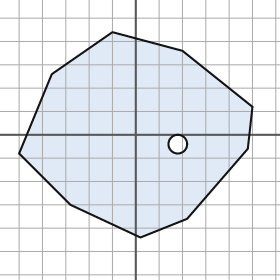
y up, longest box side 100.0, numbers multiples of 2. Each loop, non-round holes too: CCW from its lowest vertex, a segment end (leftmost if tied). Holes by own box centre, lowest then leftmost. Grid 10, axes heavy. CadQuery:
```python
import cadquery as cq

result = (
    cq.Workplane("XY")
    .moveTo(2.0, -44.0)
    .lineTo(22.0, -36.0)
    .lineTo(48.0, -6.0)
    .lineTo(50.0, 12.0)
    .lineTo(20.0, 36.0)
    .lineTo(-10.0, 44.0)
    .lineTo(-36.0, 26.0)
    .lineTo(-50.0, -8.0)
    .lineTo(-28.0, -30.0)
    .close()
    .moveTo(18.0, -4.0)
    .circle(4.0)
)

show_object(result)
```